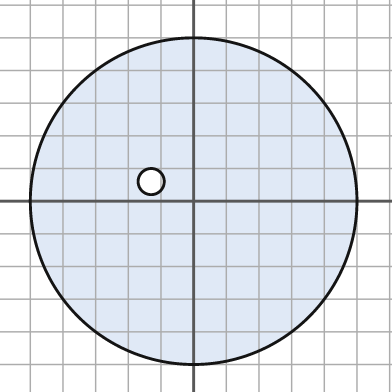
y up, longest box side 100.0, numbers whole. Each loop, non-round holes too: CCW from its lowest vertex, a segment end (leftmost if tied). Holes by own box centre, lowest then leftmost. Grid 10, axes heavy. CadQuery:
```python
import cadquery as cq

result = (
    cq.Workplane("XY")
    .moveTo(0.0, 0.0)
    .circle(50.0)
    .moveTo(-13.0, 6.0)
    .circle(4.0)
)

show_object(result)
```